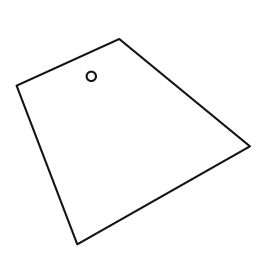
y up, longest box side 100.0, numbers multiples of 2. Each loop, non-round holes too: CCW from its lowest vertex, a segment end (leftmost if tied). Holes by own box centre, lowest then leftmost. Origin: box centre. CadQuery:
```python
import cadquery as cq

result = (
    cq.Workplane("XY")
    .moveTo(-24.0, -44.0)
    .lineTo(50.0, -2.0)
    .lineTo(-6.0, 44.0)
    .lineTo(-50.0, 24.0)
    .close()
    .moveTo(-18.0, 28.0)
    .circle(2.0)
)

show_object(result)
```